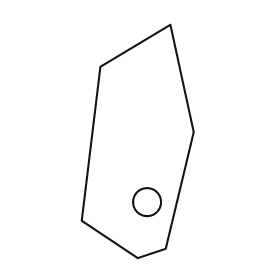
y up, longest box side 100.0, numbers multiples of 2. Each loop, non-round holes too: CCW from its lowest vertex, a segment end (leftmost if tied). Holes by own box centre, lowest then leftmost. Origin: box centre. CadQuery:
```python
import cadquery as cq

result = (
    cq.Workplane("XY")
    .moveTo(0.0, -50.0)
    .lineTo(12.0, -46.0)
    .lineTo(24.0, 4.0)
    .lineTo(14.0, 50.0)
    .lineTo(-16.0, 32.0)
    .lineTo(-24.0, -34.0)
    .close()
    .moveTo(4.0, -26.0)
    .circle(6.0)
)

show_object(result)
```